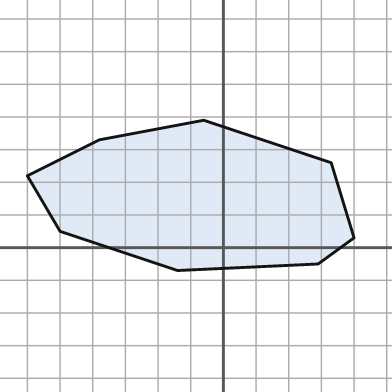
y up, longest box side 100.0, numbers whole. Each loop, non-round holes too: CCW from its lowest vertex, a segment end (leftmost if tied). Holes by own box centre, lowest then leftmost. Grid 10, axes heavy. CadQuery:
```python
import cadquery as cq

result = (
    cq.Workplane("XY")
    .moveTo(-14.0, -7.0)
    .lineTo(29.0, -5.0)
    .lineTo(40.0, 3.0)
    .lineTo(33.0, 26.0)
    .lineTo(-6.0, 39.0)
    .lineTo(-38.0, 33.0)
    .lineTo(-60.0, 22.0)
    .lineTo(-50.0, 5.0)
    .close()
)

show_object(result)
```